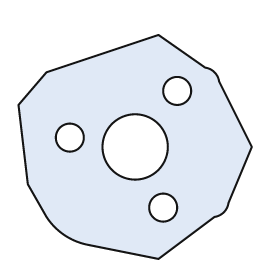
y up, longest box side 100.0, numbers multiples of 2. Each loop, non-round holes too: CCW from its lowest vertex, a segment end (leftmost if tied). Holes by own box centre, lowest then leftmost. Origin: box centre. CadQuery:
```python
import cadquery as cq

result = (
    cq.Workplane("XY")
    .moveTo(10.0, -48.0)
    .lineTo(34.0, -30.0)
    .threePointArc((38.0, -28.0), (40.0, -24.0))
    .lineTo(50.0, 0.0)
    .lineTo(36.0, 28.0)
    .threePointArc((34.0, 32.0), (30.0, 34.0))
    .lineTo(10.0, 48.0)
    .lineTo(-38.0, 32.0)
    .lineTo(-50.0, 18.0)
    .lineTo(-46.0, -16.0)
    .lineTo(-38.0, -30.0)
    .threePointArc((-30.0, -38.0), (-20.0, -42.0))
    .close()
    .moveTo(12.0, -26.0)
    .circle(6.0)
    .moveTo(0.0, 0.0)
    .circle(14.0)
    .moveTo(-28.0, 4.0)
    .circle(6.0)
    .moveTo(18.0, 24.0)
    .circle(6.0)
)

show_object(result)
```